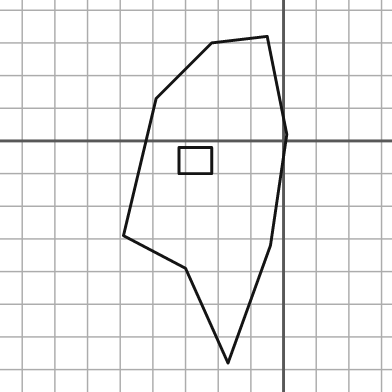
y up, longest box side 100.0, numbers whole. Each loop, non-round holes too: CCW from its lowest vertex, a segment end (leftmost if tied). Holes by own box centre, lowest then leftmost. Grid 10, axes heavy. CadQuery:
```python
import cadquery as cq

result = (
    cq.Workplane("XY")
    .moveTo(-17.0, -68.0)
    .lineTo(-4.0, -32.0)
    .lineTo(1.0, 2.0)
    .lineTo(-5.0, 32.0)
    .lineTo(-22.0, 30.0)
    .lineTo(-39.0, 13.0)
    .lineTo(-49.0, -29.0)
    .lineTo(-30.0, -39.0)
    .close()
    .moveTo(-32.0, -10.0)
    .lineTo(-22.0, -10.0)
    .lineTo(-22.0, -2.0)
    .lineTo(-32.0, -2.0)
    .close()
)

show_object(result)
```